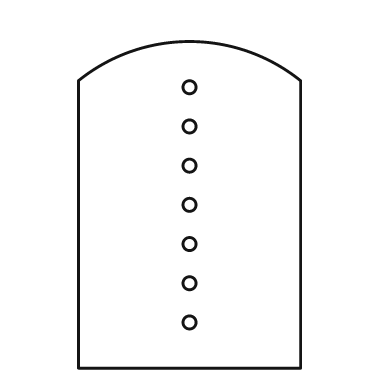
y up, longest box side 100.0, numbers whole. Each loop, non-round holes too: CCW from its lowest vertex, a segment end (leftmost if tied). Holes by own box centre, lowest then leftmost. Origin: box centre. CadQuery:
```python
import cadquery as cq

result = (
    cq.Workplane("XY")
    .moveTo(-34.0, -50.0)
    .lineTo(34.0, -50.0)
    .lineTo(34.0, 38.0)
    .threePointArc((0.0, 50.0), (-34.0, 38.0))
    .close()
    .moveTo(0.0, -36.0)
    .circle(2.0)
    .moveTo(0.0, -24.0)
    .circle(2.0)
    .moveTo(0.0, -12.0)
    .circle(2.0)
    .moveTo(0.0, 0.0)
    .circle(2.0)
    .moveTo(0.0, 12.0)
    .circle(2.0)
    .moveTo(0.0, 24.0)
    .circle(2.0)
    .moveTo(0.0, 36.0)
    .circle(2.0)
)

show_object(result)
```